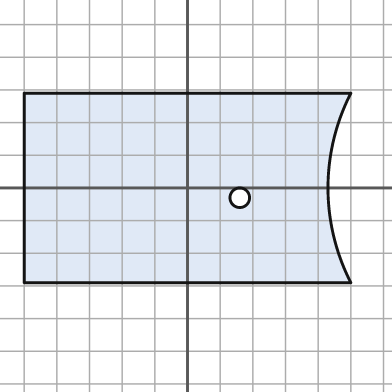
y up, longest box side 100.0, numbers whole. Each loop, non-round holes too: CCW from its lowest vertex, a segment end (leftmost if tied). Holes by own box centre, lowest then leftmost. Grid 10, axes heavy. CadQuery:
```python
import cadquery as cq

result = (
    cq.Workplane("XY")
    .moveTo(-50.0, -29.0)
    .lineTo(50.0, -29.0)
    .threePointArc((43.0, 0.0), (50.0, 29.0))
    .lineTo(-50.0, 29.0)
    .close()
    .moveTo(16.0, -3.0)
    .circle(3.0)
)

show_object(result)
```